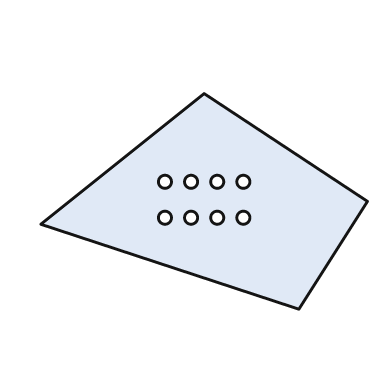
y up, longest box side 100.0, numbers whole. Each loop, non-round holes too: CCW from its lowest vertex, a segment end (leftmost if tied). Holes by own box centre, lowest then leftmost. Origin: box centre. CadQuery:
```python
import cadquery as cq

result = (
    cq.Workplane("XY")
    .moveTo(29.0, -33.0)
    .lineTo(50.0, 0.0)
    .lineTo(0.0, 33.0)
    .lineTo(-50.0, -7.0)
    .close()
    .moveTo(-12.0, -5.0)
    .circle(2.0)
    .moveTo(-4.0, -5.0)
    .circle(2.0)
    .moveTo(4.0, -5.0)
    .circle(2.0)
    .moveTo(12.0, -5.0)
    .circle(2.0)
    .moveTo(-12.0, 6.0)
    .circle(2.0)
    .moveTo(-4.0, 6.0)
    .circle(2.0)
    .moveTo(4.0, 6.0)
    .circle(2.0)
    .moveTo(12.0, 6.0)
    .circle(2.0)
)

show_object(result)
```